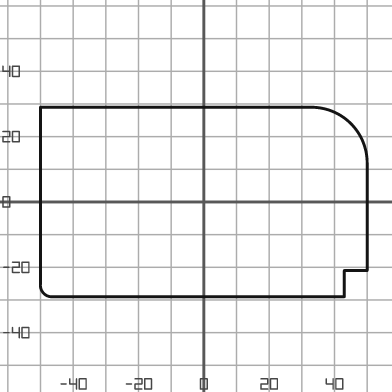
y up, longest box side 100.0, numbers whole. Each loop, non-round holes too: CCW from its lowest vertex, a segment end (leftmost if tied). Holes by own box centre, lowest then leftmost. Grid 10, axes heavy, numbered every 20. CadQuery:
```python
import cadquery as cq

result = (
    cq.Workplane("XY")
    .moveTo(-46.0, -29.0)
    .lineTo(43.0, -29.0)
    .lineTo(43.0, -21.0)
    .lineTo(50.0, -21.0)
    .lineTo(50.0, 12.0)
    .threePointArc((45.0, 24.0), (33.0, 29.0))
    .lineTo(-50.0, 29.0)
    .lineTo(-50.0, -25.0)
    .threePointArc((-49.0, -28.0), (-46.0, -29.0))
    .close()
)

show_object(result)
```